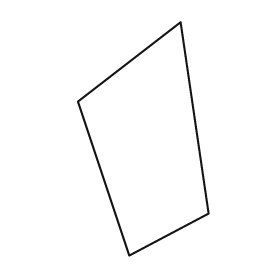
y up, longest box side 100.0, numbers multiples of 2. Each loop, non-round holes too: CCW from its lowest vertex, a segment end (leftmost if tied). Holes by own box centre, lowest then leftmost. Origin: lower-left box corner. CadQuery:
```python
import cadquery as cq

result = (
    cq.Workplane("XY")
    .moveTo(22.0, 0.0)
    .lineTo(56.0, 18.0)
    .lineTo(44.0, 100.0)
    .lineTo(0.0, 66.0)
    .close()
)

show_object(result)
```